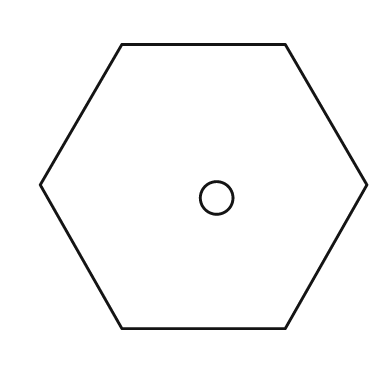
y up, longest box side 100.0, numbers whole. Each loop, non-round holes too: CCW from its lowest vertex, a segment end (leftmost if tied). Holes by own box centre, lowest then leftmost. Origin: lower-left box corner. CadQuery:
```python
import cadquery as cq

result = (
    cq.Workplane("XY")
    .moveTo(25.0, 0.0)
    .lineTo(75.0, 0.0)
    .lineTo(100.0, 44.0)
    .lineTo(75.0, 87.0)
    .lineTo(25.0, 87.0)
    .lineTo(0.0, 44.0)
    .close()
    .moveTo(54.0, 40.0)
    .circle(5.0)
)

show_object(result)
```